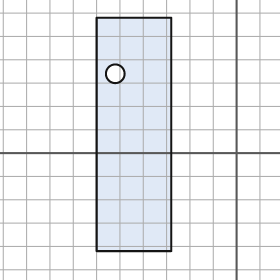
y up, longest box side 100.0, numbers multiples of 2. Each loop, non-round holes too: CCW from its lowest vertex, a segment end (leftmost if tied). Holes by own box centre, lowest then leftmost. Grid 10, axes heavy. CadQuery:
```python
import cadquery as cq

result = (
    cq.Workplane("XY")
    .moveTo(-60.0, -42.0)
    .lineTo(-28.0, -42.0)
    .lineTo(-28.0, 58.0)
    .lineTo(-60.0, 58.0)
    .close()
    .moveTo(-52.0, 34.0)
    .circle(4.0)
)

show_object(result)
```